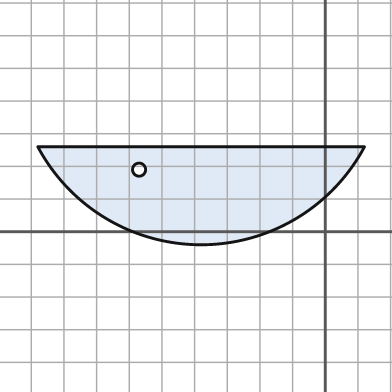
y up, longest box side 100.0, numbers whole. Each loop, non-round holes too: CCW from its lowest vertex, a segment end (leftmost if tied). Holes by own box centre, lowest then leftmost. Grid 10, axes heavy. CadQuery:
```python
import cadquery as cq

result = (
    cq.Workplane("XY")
    .moveTo(-88.0, 26.0)
    .threePointArc((-38.0, -4.0), (12.0, 26.0))
    .close()
    .moveTo(-57.0, 19.0)
    .circle(2.0)
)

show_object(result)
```